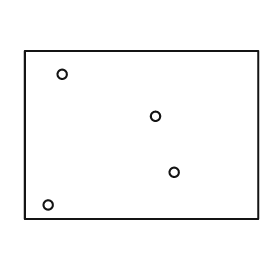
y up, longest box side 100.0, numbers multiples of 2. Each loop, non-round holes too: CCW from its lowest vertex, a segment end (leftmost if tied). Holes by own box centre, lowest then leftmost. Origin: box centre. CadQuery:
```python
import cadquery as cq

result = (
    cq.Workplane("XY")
    .moveTo(-50.0, -36.0)
    .lineTo(50.0, -36.0)
    .lineTo(50.0, 36.0)
    .lineTo(-50.0, 36.0)
    .close()
    .moveTo(-40.0, -30.0)
    .circle(2.0)
    .moveTo(14.0, -16.0)
    .circle(2.0)
    .moveTo(6.0, 8.0)
    .circle(2.0)
    .moveTo(-34.0, 26.0)
    .circle(2.0)
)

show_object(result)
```